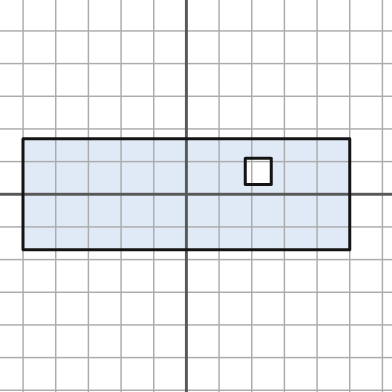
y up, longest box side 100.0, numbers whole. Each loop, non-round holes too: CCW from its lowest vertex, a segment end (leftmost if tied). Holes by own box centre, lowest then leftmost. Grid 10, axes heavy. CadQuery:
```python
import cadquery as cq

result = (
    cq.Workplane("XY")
    .moveTo(-50.0, -17.0)
    .lineTo(50.0, -17.0)
    .lineTo(50.0, 17.0)
    .lineTo(-50.0, 17.0)
    .close()
    .moveTo(18.0, 3.0)
    .lineTo(26.0, 3.0)
    .lineTo(26.0, 11.0)
    .lineTo(18.0, 11.0)
    .close()
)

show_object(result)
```